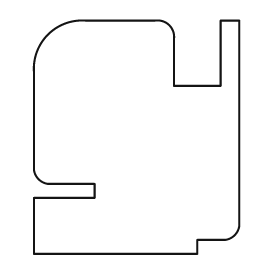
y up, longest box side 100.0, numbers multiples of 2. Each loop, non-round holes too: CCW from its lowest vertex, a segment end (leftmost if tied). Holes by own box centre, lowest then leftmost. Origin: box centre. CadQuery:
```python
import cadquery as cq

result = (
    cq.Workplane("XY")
    .moveTo(-44.0, -50.0)
    .lineTo(26.0, -50.0)
    .lineTo(26.0, -44.0)
    .lineTo(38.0, -44.0)
    .threePointArc((42.0, -42.0), (44.0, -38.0))
    .lineTo(44.0, 50.0)
    .lineTo(36.0, 50.0)
    .lineTo(36.0, 22.0)
    .lineTo(16.0, 22.0)
    .lineTo(16.0, 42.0)
    .threePointArc((14.0, 48.0), (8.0, 50.0))
    .lineTo(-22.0, 50.0)
    .threePointArc((-38.0, 44.0), (-44.0, 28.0))
    .lineTo(-44.0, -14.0)
    .threePointArc((-42.0, -18.0), (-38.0, -20.0))
    .lineTo(-18.0, -20.0)
    .lineTo(-18.0, -26.0)
    .lineTo(-44.0, -26.0)
    .close()
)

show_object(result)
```